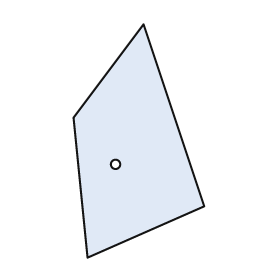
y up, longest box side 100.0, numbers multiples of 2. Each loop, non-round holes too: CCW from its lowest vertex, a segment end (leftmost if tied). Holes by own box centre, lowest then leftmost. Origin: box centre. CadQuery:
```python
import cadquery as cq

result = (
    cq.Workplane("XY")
    .moveTo(-22.0, -50.0)
    .lineTo(28.0, -28.0)
    .lineTo(2.0, 50.0)
    .lineTo(-28.0, 10.0)
    .close()
    .moveTo(-10.0, -10.0)
    .circle(2.0)
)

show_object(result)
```